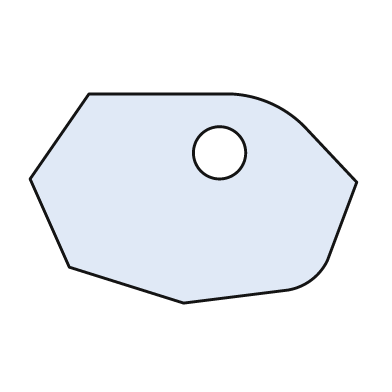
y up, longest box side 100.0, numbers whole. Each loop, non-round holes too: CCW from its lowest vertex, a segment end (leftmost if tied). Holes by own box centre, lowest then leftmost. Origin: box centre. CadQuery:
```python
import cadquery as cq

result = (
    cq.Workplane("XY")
    .moveTo(-3.0, -32.0)
    .lineTo(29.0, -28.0)
    .threePointArc((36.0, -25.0), (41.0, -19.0))
    .lineTo(50.0, 5.0)
    .lineTo(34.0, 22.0)
    .threePointArc((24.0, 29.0), (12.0, 32.0))
    .lineTo(-32.0, 32.0)
    .lineTo(-50.0, 6.0)
    .lineTo(-38.0, -21.0)
    .close()
    .moveTo(8.0, 14.0)
    .circle(8.0)
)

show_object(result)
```